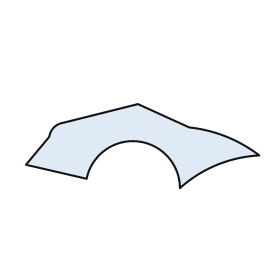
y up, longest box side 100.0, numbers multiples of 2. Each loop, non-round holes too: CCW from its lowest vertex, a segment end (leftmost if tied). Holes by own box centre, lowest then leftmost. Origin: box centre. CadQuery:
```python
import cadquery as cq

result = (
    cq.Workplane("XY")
    .moveTo(16.0, -18.0)
    .threePointArc((32.0, -8.0), (50.0, -4.0))
    .threePointArc((36.0, 4.0), (20.0, 8.0))
    .lineTo(-2.0, 18.0)
    .lineTo(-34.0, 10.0)
    .threePointArc((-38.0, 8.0), (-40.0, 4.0))
    .lineTo(-50.0, -8.0)
    .lineTo(-24.0, -14.0)
    .threePointArc((-2.0, 2.0), (16.0, -18.0))
    .close()
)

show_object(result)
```